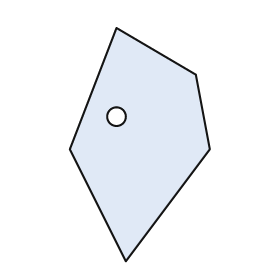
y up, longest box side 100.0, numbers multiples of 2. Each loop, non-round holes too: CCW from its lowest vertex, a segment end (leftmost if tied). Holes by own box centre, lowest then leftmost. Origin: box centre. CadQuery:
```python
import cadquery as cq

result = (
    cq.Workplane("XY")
    .moveTo(-6.0, -50.0)
    .lineTo(30.0, -2.0)
    .lineTo(24.0, 30.0)
    .lineTo(-10.0, 50.0)
    .lineTo(-30.0, -2.0)
    .close()
    .moveTo(-10.0, 12.0)
    .circle(4.0)
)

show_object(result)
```